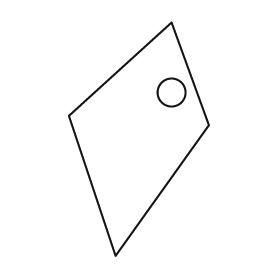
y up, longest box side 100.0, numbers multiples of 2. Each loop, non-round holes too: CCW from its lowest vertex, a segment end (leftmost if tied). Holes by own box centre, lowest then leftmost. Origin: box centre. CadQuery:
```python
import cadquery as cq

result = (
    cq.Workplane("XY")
    .moveTo(-10.0, -50.0)
    .lineTo(30.0, 6.0)
    .lineTo(14.0, 50.0)
    .lineTo(-30.0, 10.0)
    .close()
    .moveTo(14.0, 20.0)
    .circle(6.0)
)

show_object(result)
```